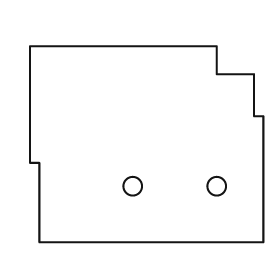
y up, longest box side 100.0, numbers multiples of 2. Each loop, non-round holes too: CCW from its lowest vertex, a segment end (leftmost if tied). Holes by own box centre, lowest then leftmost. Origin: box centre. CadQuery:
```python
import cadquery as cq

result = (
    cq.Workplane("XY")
    .moveTo(-46.0, -42.0)
    .lineTo(50.0, -42.0)
    .lineTo(50.0, 12.0)
    .lineTo(46.0, 12.0)
    .lineTo(46.0, 30.0)
    .lineTo(30.0, 30.0)
    .lineTo(30.0, 42.0)
    .lineTo(-50.0, 42.0)
    .lineTo(-50.0, -8.0)
    .lineTo(-46.0, -8.0)
    .close()
    .moveTo(-6.0, -18.0)
    .circle(4.0)
    .moveTo(30.0, -18.0)
    .circle(4.0)
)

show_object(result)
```